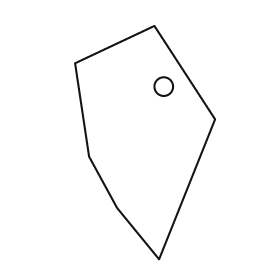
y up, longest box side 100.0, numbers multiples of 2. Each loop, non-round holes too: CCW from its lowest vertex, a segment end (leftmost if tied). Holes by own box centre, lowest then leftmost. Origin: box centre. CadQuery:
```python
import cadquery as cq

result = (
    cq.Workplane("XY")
    .moveTo(6.0, -50.0)
    .lineTo(30.0, 10.0)
    .lineTo(4.0, 50.0)
    .lineTo(-30.0, 34.0)
    .lineTo(-24.0, -6.0)
    .lineTo(-12.0, -28.0)
    .close()
    .moveTo(8.0, 24.0)
    .circle(4.0)
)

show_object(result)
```